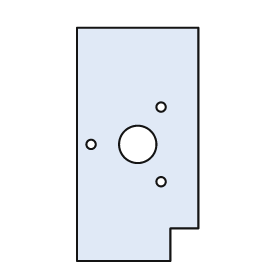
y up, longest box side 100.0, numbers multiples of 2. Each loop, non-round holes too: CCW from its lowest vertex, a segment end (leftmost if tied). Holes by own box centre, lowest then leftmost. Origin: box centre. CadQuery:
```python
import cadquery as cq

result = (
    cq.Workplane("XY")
    .moveTo(-26.0, -50.0)
    .lineTo(14.0, -50.0)
    .lineTo(14.0, -36.0)
    .lineTo(26.0, -36.0)
    .lineTo(26.0, 50.0)
    .lineTo(-26.0, 50.0)
    .close()
    .moveTo(10.0, -16.0)
    .circle(2.0)
    .moveTo(-20.0, 0.0)
    .circle(2.0)
    .moveTo(0.0, 0.0)
    .circle(8.0)
    .moveTo(10.0, 16.0)
    .circle(2.0)
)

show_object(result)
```